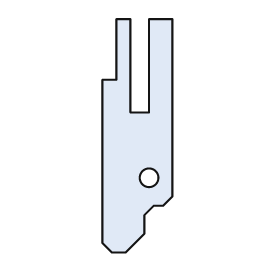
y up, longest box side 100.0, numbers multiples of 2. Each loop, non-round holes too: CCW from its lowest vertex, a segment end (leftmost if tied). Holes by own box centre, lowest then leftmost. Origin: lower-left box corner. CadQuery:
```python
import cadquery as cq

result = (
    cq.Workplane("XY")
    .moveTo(4.0, 0.0)
    .lineTo(10.0, 0.0)
    .lineTo(18.0, 8.0)
    .lineTo(18.0, 16.0)
    .lineTo(22.0, 20.0)
    .lineTo(26.0, 20.0)
    .lineTo(30.0, 24.0)
    .lineTo(30.0, 100.0)
    .lineTo(20.0, 100.0)
    .lineTo(20.0, 60.0)
    .lineTo(12.0, 60.0)
    .lineTo(12.0, 100.0)
    .lineTo(6.0, 100.0)
    .lineTo(6.0, 74.0)
    .lineTo(0.0, 74.0)
    .lineTo(0.0, 4.0)
    .close()
    .moveTo(20.0, 32.0)
    .circle(4.0)
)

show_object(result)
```